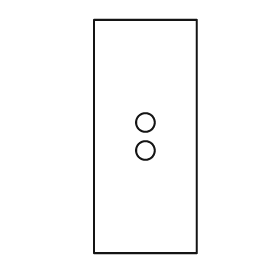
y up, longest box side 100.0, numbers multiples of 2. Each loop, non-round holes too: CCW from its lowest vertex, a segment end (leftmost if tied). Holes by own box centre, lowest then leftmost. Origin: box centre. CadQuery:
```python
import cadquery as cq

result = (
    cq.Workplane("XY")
    .moveTo(-22.0, -50.0)
    .lineTo(22.0, -50.0)
    .lineTo(22.0, 50.0)
    .lineTo(-22.0, 50.0)
    .close()
    .moveTo(0.0, -6.0)
    .circle(4.0)
    .moveTo(0.0, 6.0)
    .circle(4.0)
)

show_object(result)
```